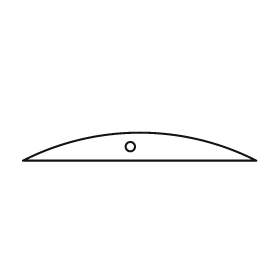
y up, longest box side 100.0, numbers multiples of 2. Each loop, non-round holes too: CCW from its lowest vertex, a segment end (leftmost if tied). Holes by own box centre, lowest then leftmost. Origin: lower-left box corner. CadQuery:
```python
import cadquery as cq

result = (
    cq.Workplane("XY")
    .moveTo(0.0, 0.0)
    .lineTo(100.0, 0.0)
    .threePointArc((50.0, 12.0), (0.0, 0.0))
    .close()
    .moveTo(46.0, 6.0)
    .circle(2.0)
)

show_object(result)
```